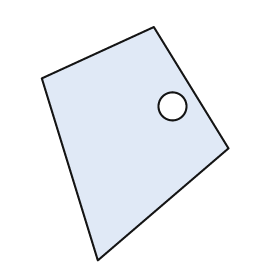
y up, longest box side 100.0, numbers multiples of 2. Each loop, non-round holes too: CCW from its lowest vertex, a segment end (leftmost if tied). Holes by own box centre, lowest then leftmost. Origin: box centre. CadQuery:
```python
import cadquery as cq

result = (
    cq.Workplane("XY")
    .moveTo(-16.0, -50.0)
    .lineTo(40.0, -2.0)
    .lineTo(8.0, 50.0)
    .lineTo(-40.0, 28.0)
    .close()
    .moveTo(16.0, 16.0)
    .circle(6.0)
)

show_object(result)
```